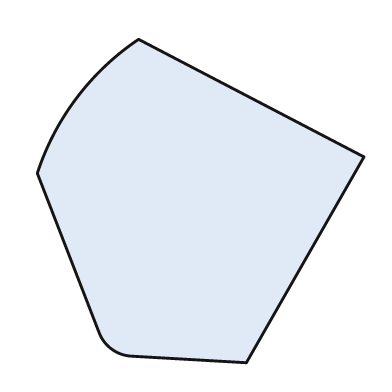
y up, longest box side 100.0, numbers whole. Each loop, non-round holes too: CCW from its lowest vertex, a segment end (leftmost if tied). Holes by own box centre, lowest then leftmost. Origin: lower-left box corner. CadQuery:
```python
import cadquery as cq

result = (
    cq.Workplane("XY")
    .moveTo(64.0, 0.0)
    .lineTo(100.0, 63.0)
    .lineTo(31.0, 99.0)
    .threePointArc((12.0, 81.0), (0.0, 58.0))
    .lineTo(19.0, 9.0)
    .threePointArc((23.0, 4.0), (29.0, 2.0))
    .close()
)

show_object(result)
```